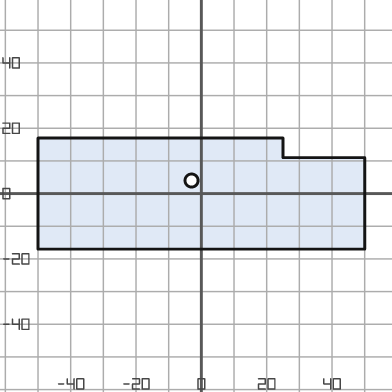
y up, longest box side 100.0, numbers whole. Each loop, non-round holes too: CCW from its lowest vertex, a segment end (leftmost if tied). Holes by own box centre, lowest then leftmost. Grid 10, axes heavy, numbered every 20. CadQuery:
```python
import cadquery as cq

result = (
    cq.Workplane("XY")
    .moveTo(-50.0, -17.0)
    .lineTo(50.0, -17.0)
    .lineTo(50.0, 11.0)
    .lineTo(25.0, 11.0)
    .lineTo(25.0, 17.0)
    .lineTo(-50.0, 17.0)
    .close()
    .moveTo(-3.0, 4.0)
    .circle(2.0)
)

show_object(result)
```